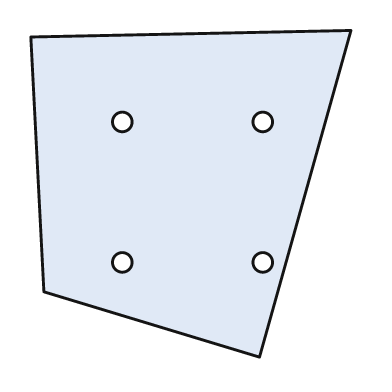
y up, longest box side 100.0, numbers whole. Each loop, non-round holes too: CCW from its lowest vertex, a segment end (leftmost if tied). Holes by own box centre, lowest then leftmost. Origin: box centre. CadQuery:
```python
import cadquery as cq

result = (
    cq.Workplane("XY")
    .moveTo(21.0, -50.0)
    .lineTo(49.0, 50.0)
    .lineTo(-49.0, 48.0)
    .lineTo(-45.0, -30.0)
    .close()
    .moveTo(-21.0, -21.0)
    .circle(3.0)
    .moveTo(22.0, -21.0)
    .circle(3.0)
    .moveTo(-21.0, 22.0)
    .circle(3.0)
    .moveTo(22.0, 22.0)
    .circle(3.0)
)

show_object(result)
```